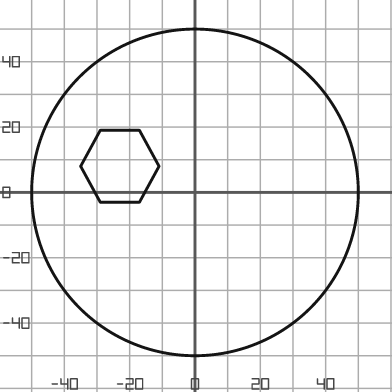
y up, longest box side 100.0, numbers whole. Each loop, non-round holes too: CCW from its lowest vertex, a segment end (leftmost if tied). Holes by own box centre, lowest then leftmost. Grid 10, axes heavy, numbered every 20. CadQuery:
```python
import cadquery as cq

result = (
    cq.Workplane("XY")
    .moveTo(0.0, 0.0)
    .circle(50.0)
    .moveTo(-29.0, -3.0)
    .lineTo(-17.0, -3.0)
    .lineTo(-11.0, 8.0)
    .lineTo(-17.0, 19.0)
    .lineTo(-29.0, 19.0)
    .lineTo(-35.0, 8.0)
    .close()
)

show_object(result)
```